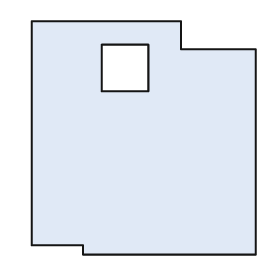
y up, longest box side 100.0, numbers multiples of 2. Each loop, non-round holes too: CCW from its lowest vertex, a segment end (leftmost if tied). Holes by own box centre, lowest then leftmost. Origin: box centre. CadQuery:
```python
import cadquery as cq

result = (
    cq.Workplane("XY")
    .moveTo(-26.0, -50.0)
    .lineTo(48.0, -50.0)
    .lineTo(48.0, 38.0)
    .lineTo(16.0, 38.0)
    .lineTo(16.0, 50.0)
    .lineTo(-48.0, 50.0)
    .lineTo(-48.0, -46.0)
    .lineTo(-26.0, -46.0)
    .close()
    .moveTo(-18.0, 20.0)
    .lineTo(2.0, 20.0)
    .lineTo(2.0, 40.0)
    .lineTo(-18.0, 40.0)
    .close()
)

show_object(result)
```